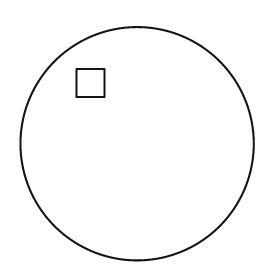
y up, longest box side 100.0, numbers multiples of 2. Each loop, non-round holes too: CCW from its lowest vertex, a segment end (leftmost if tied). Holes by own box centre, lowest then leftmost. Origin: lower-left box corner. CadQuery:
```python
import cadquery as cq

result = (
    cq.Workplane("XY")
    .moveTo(50.0, 50.0)
    .circle(50.0)
    .moveTo(24.0, 70.0)
    .lineTo(36.0, 70.0)
    .lineTo(36.0, 82.0)
    .lineTo(24.0, 82.0)
    .close()
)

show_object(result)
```